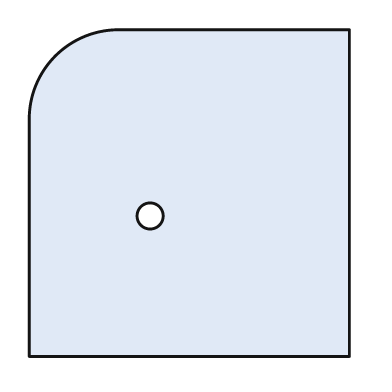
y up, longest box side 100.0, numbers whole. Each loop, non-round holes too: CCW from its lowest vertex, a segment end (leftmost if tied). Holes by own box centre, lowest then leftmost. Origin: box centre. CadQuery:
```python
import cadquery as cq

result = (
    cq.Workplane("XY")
    .moveTo(-49.0, -50.0)
    .lineTo(49.0, -50.0)
    .lineTo(49.0, 50.0)
    .lineTo(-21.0, 50.0)
    .threePointArc((-41.0, 42.0), (-49.0, 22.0))
    .close()
    .moveTo(-12.0, -7.0)
    .circle(4.0)
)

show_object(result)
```